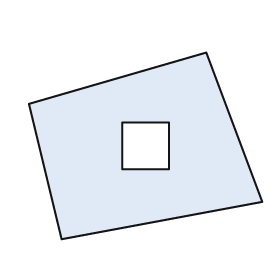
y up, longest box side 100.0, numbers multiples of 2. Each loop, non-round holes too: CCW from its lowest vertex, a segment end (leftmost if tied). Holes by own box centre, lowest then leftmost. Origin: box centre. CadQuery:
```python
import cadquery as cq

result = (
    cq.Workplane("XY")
    .moveTo(-36.0, -40.0)
    .lineTo(50.0, -24.0)
    .lineTo(26.0, 40.0)
    .lineTo(-50.0, 18.0)
    .close()
    .moveTo(-10.0, -10.0)
    .lineTo(10.0, -10.0)
    .lineTo(10.0, 10.0)
    .lineTo(-10.0, 10.0)
    .close()
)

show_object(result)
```